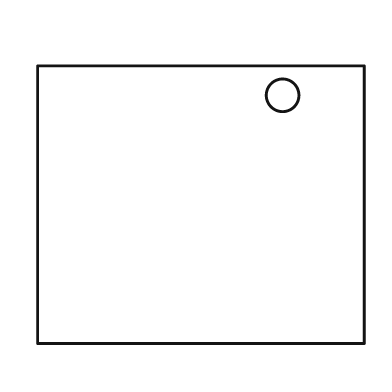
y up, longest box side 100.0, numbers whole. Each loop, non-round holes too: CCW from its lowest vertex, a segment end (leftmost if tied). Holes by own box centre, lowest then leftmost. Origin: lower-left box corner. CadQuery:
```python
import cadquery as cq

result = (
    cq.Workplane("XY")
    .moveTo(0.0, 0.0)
    .lineTo(100.0, 0.0)
    .lineTo(100.0, 85.0)
    .lineTo(0.0, 85.0)
    .close()
    .moveTo(75.0, 76.0)
    .circle(5.0)
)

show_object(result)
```